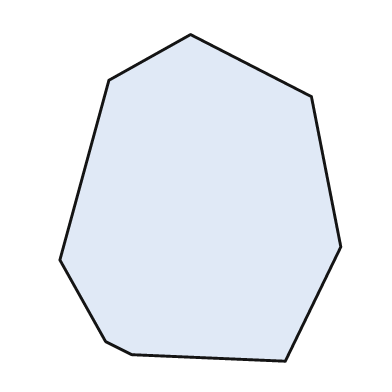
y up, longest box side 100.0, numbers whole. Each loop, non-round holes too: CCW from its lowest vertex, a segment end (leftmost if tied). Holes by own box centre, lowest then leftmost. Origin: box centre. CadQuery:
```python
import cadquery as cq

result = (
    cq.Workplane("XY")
    .moveTo(26.0, -50.0)
    .lineTo(43.0, -15.0)
    .lineTo(34.0, 31.0)
    .lineTo(-3.0, 50.0)
    .lineTo(-28.0, 36.0)
    .lineTo(-43.0, -19.0)
    .lineTo(-29.0, -44.0)
    .lineTo(-21.0, -48.0)
    .close()
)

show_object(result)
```